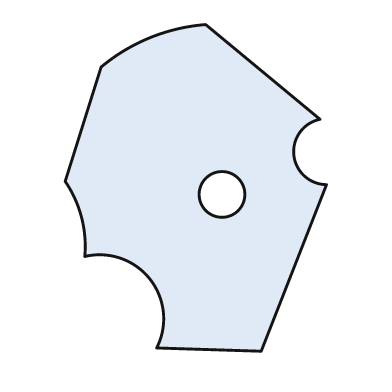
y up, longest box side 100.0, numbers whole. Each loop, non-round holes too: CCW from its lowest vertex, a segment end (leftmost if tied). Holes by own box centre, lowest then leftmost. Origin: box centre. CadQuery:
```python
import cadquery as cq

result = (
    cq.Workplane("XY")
    .moveTo(20.0, -50.0)
    .lineTo(40.0, 1.0)
    .threePointArc((30.0, 10.0), (38.0, 21.0))
    .lineTo(3.0, 50.0)
    .threePointArc((-14.0, 46.0), (-29.0, 37.0))
    .lineTo(-40.0, 2.0)
    .threePointArc((-35.0, -9.0), (-34.0, -21.0))
    .threePointArc((-14.0, -28.0), (-12.0, -49.0))
    .close()
    .moveTo(8.0, -2.0)
    .circle(7.0)
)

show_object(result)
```